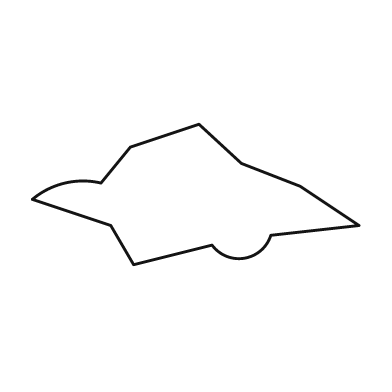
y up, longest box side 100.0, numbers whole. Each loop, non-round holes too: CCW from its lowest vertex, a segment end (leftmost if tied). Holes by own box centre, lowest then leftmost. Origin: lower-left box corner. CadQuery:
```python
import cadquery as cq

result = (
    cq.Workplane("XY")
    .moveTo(31.0, 0.0)
    .lineTo(55.0, 6.0)
    .threePointArc((65.0, 2.0), (73.0, 9.0))
    .lineTo(100.0, 12.0)
    .lineTo(82.0, 24.0)
    .lineTo(64.0, 31.0)
    .lineTo(51.0, 43.0)
    .lineTo(30.0, 36.0)
    .lineTo(21.0, 25.0)
    .threePointArc((10.0, 25.0), (0.0, 20.0))
    .lineTo(24.0, 12.0)
    .close()
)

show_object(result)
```